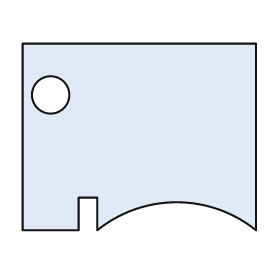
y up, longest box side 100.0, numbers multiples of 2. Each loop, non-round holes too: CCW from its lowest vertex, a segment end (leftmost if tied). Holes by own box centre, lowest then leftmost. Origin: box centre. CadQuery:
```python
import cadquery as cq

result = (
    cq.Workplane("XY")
    .moveTo(-50.0, -40.0)
    .lineTo(-26.0, -40.0)
    .lineTo(-26.0, -26.0)
    .lineTo(-18.0, -26.0)
    .lineTo(-18.0, -40.0)
    .threePointArc((16.0, -28.0), (50.0, -40.0))
    .lineTo(50.0, 40.0)
    .lineTo(-50.0, 40.0)
    .close()
    .moveTo(-38.0, 18.0)
    .circle(8.0)
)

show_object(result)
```